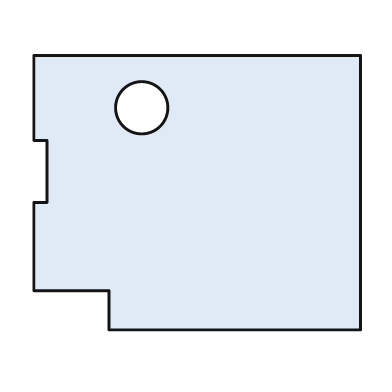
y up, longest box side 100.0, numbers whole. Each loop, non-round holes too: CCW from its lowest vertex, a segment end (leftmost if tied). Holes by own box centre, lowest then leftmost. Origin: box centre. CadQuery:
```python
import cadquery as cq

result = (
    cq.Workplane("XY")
    .moveTo(-27.0, -42.0)
    .lineTo(50.0, -42.0)
    .lineTo(50.0, 42.0)
    .lineTo(-50.0, 42.0)
    .lineTo(-50.0, 16.0)
    .lineTo(-46.0, 16.0)
    .lineTo(-46.0, -3.0)
    .lineTo(-50.0, -3.0)
    .lineTo(-50.0, -30.0)
    .lineTo(-27.0, -30.0)
    .close()
    .moveTo(-17.0, 26.0)
    .circle(8.0)
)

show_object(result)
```